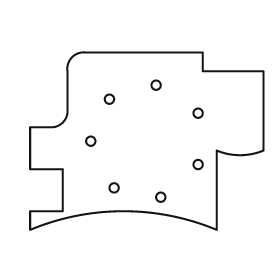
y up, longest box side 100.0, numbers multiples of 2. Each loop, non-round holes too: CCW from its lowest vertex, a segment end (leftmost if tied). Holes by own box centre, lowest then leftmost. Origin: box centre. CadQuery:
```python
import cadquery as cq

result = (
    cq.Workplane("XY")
    .moveTo(-50.0, -38.0)
    .threePointArc((-10.0, -30.0), (30.0, -38.0))
    .lineTo(30.0, -4.0)
    .threePointArc((40.0, -6.0), (50.0, -4.0))
    .lineTo(50.0, 30.0)
    .lineTo(24.0, 30.0)
    .lineTo(24.0, 38.0)
    .lineTo(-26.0, 38.0)
    .threePointArc((-32.0, 36.0), (-34.0, 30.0))
    .lineTo(-34.0, 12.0)
    .threePointArc((-36.0, 8.0), (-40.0, 6.0))
    .lineTo(-50.0, 6.0)
    .lineTo(-50.0, -12.0)
    .lineTo(-36.0, -12.0)
    .lineTo(-36.0, -30.0)
    .lineTo(-50.0, -30.0)
    .close()
    .moveTo(6.0, -24.0)
    .circle(2.0)
    .moveTo(-14.0, -20.0)
    .circle(2.0)
    .moveTo(22.0, -10.0)
    .circle(2.0)
    .moveTo(-24.0, 0.0)
    .circle(2.0)
    .moveTo(22.0, 12.0)
    .circle(2.0)
    .moveTo(-16.0, 18.0)
    .circle(2.0)
    .moveTo(4.0, 24.0)
    .circle(2.0)
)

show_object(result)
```